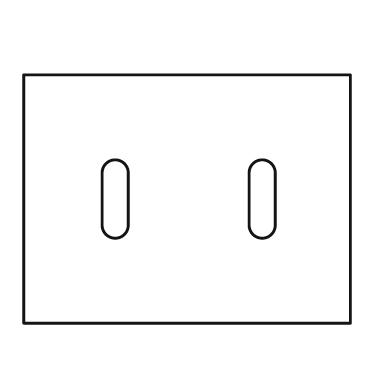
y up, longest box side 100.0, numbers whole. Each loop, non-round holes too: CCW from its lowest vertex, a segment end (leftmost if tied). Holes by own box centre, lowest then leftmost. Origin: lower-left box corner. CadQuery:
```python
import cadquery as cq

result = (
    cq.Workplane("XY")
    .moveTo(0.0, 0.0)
    .lineTo(100.0, 0.0)
    .lineTo(100.0, 76.0)
    .lineTo(0.0, 76.0)
    .close()
    .moveTo(24.0, 30.0)
    .threePointArc((28.0, 26.0), (32.0, 30.0))
    .lineTo(32.0, 46.0)
    .threePointArc((28.0, 50.0), (24.0, 46.0))
    .close()
    .moveTo(69.0, 30.0)
    .threePointArc((73.0, 26.0), (77.0, 30.0))
    .lineTo(77.0, 46.0)
    .threePointArc((73.0, 50.0), (69.0, 46.0))
    .close()
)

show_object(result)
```